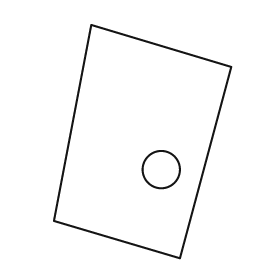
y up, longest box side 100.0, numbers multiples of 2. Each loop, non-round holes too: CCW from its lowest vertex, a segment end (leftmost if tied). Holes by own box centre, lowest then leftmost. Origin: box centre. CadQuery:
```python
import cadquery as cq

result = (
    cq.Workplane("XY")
    .moveTo(16.0, -50.0)
    .lineTo(38.0, 32.0)
    .lineTo(-22.0, 50.0)
    .lineTo(-38.0, -34.0)
    .close()
    .moveTo(8.0, -12.0)
    .circle(8.0)
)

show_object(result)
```